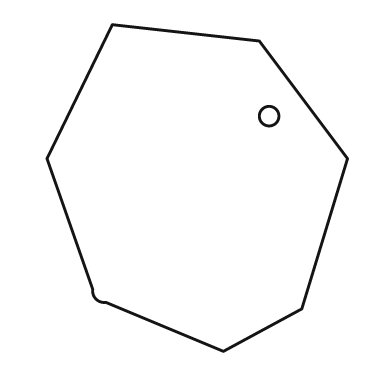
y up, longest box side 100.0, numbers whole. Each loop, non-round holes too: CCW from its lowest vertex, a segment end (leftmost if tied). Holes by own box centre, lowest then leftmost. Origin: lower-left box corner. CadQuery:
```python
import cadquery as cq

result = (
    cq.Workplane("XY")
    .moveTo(54.0, 0.0)
    .lineTo(78.0, 13.0)
    .lineTo(92.0, 59.0)
    .lineTo(65.0, 95.0)
    .lineTo(20.0, 100.0)
    .lineTo(0.0, 59.0)
    .lineTo(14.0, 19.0)
    .threePointArc((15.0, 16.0), (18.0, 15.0))
    .close()
    .moveTo(68.0, 72.0)
    .circle(3.0)
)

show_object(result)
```